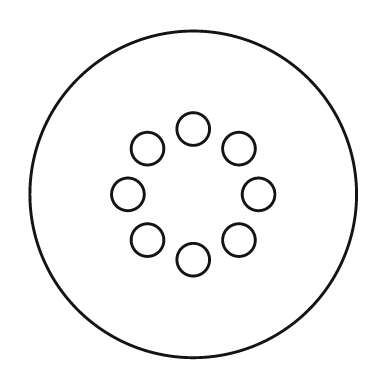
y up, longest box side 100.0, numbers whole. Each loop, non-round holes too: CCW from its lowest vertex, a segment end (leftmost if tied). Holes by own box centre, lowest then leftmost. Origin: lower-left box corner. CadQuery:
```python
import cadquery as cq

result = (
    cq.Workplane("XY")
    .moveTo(50.0, 50.0)
    .circle(50.0)
    .moveTo(50.0, 30.0)
    .circle(5.0)
    .moveTo(36.0, 36.0)
    .circle(5.0)
    .moveTo(64.0, 36.0)
    .circle(5.0)
    .moveTo(30.0, 50.0)
    .circle(5.0)
    .moveTo(70.0, 50.0)
    .circle(5.0)
    .moveTo(36.0, 64.0)
    .circle(5.0)
    .moveTo(64.0, 64.0)
    .circle(5.0)
    .moveTo(50.0, 70.0)
    .circle(5.0)
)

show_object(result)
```